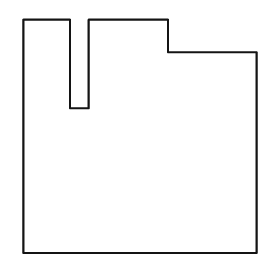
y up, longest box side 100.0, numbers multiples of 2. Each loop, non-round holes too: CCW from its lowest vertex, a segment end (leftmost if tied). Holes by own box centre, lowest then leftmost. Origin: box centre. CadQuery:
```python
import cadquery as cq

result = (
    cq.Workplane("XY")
    .moveTo(-50.0, -50.0)
    .lineTo(50.0, -50.0)
    .lineTo(50.0, 36.0)
    .lineTo(12.0, 36.0)
    .lineTo(12.0, 50.0)
    .lineTo(-22.0, 50.0)
    .lineTo(-22.0, 12.0)
    .lineTo(-30.0, 12.0)
    .lineTo(-30.0, 50.0)
    .lineTo(-50.0, 50.0)
    .close()
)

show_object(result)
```